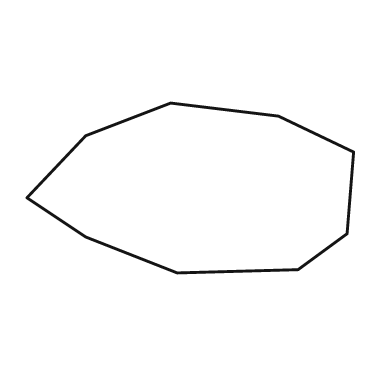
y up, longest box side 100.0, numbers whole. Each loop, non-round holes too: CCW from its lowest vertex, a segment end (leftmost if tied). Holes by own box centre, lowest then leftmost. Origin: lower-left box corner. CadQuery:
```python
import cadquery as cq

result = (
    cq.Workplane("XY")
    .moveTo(46.0, 0.0)
    .lineTo(83.0, 1.0)
    .lineTo(98.0, 12.0)
    .lineTo(100.0, 37.0)
    .lineTo(77.0, 48.0)
    .lineTo(44.0, 52.0)
    .lineTo(18.0, 42.0)
    .lineTo(0.0, 23.0)
    .lineTo(18.0, 11.0)
    .close()
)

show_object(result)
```